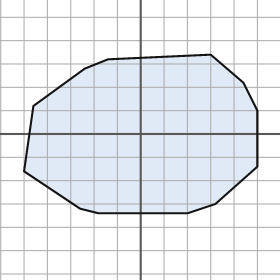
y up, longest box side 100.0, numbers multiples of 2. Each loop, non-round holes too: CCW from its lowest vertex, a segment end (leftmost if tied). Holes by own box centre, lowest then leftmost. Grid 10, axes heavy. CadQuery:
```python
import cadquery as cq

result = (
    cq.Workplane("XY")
    .moveTo(-18.0, -34.0)
    .lineTo(20.0, -34.0)
    .lineTo(32.0, -30.0)
    .lineTo(50.0, -14.0)
    .lineTo(50.0, 10.0)
    .lineTo(44.0, 22.0)
    .lineTo(30.0, 34.0)
    .lineTo(-14.0, 32.0)
    .lineTo(-24.0, 28.0)
    .lineTo(-46.0, 12.0)
    .lineTo(-50.0, -16.0)
    .lineTo(-26.0, -32.0)
    .close()
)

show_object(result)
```